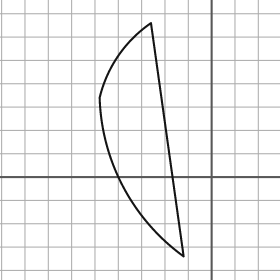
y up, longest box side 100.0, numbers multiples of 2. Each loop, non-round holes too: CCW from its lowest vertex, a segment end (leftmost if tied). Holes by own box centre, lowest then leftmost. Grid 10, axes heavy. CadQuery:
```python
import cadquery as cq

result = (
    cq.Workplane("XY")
    .moveTo(-12.0, -34.0)
    .lineTo(-26.0, 66.0)
    .threePointArc((-40.0, 52.0), (-48.0, 34.0))
    .threePointArc((-38.0, -4.0), (-12.0, -34.0))
    .close()
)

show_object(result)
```